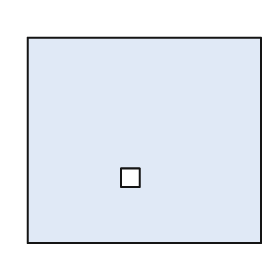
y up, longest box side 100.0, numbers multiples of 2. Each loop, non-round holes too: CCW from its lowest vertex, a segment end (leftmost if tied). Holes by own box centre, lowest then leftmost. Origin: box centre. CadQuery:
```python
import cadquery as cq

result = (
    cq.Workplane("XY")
    .moveTo(-50.0, -44.0)
    .lineTo(50.0, -44.0)
    .lineTo(50.0, 44.0)
    .lineTo(-50.0, 44.0)
    .close()
    .moveTo(-10.0, -20.0)
    .lineTo(-2.0, -20.0)
    .lineTo(-2.0, -12.0)
    .lineTo(-10.0, -12.0)
    .close()
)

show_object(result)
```